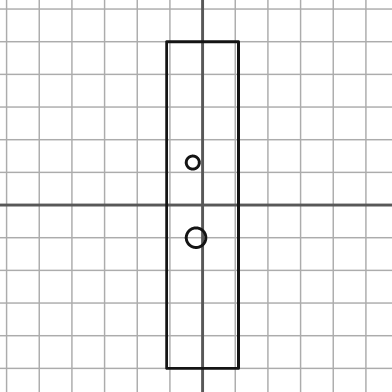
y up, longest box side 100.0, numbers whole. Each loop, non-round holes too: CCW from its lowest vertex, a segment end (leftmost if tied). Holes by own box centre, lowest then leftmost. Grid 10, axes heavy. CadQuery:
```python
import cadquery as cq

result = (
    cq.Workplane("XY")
    .moveTo(-11.0, -50.0)
    .lineTo(11.0, -50.0)
    .lineTo(11.0, 50.0)
    .lineTo(-11.0, 50.0)
    .close()
    .moveTo(-2.0, -10.0)
    .circle(3.0)
    .moveTo(-3.0, 13.0)
    .circle(2.0)
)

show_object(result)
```